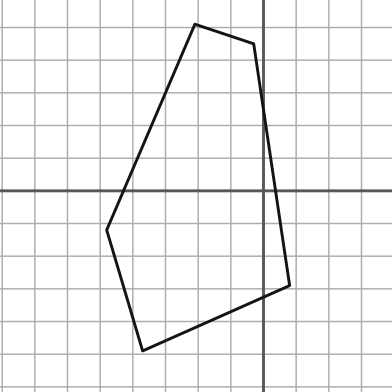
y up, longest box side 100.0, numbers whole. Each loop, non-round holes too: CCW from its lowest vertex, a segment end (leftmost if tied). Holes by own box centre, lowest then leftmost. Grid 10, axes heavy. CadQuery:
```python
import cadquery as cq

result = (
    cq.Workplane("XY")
    .moveTo(-37.0, -49.0)
    .lineTo(8.0, -29.0)
    .lineTo(-3.0, 45.0)
    .lineTo(-21.0, 51.0)
    .lineTo(-48.0, -12.0)
    .close()
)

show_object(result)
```